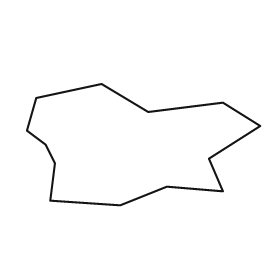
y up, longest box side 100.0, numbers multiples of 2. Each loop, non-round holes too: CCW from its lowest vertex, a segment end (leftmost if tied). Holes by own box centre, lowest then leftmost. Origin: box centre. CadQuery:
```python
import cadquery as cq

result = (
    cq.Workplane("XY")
    .moveTo(-10.0, -26.0)
    .lineTo(10.0, -18.0)
    .lineTo(34.0, -20.0)
    .lineTo(28.0, -6.0)
    .lineTo(50.0, 8.0)
    .lineTo(34.0, 18.0)
    .lineTo(2.0, 14.0)
    .lineTo(-18.0, 26.0)
    .lineTo(-46.0, 20.0)
    .lineTo(-50.0, 6.0)
    .lineTo(-42.0, 0.0)
    .lineTo(-38.0, -8.0)
    .lineTo(-40.0, -24.0)
    .close()
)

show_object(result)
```